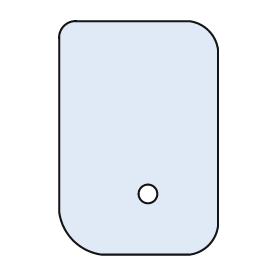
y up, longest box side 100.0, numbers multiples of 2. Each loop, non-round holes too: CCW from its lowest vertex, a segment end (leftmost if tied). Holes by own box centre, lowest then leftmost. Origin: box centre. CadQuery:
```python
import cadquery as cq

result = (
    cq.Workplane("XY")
    .moveTo(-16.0, -50.0)
    .lineTo(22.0, -50.0)
    .threePointArc((30.0, -46.0), (34.0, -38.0))
    .lineTo(34.0, 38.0)
    .threePointArc((30.0, 46.0), (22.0, 50.0))
    .lineTo(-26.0, 50.0)
    .threePointArc((-32.0, 48.0), (-34.0, 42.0))
    .lineTo(-34.0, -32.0)
    .threePointArc((-28.0, -44.0), (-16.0, -50.0))
    .close()
    .moveTo(4.0, -24.0)
    .circle(4.0)
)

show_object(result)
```